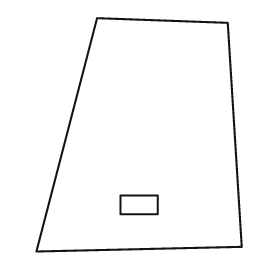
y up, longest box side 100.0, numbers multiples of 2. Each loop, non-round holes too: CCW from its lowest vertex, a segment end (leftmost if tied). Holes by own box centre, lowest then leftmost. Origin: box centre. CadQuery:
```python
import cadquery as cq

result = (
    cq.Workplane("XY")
    .moveTo(-44.0, -50.0)
    .lineTo(44.0, -48.0)
    .lineTo(38.0, 48.0)
    .lineTo(-18.0, 50.0)
    .close()
    .moveTo(-8.0, -34.0)
    .lineTo(8.0, -34.0)
    .lineTo(8.0, -26.0)
    .lineTo(-8.0, -26.0)
    .close()
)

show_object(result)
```